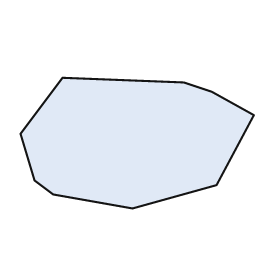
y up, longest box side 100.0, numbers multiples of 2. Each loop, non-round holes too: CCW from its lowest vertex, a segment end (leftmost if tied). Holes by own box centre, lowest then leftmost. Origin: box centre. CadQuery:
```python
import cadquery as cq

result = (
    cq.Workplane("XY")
    .moveTo(-2.0, -28.0)
    .lineTo(34.0, -18.0)
    .lineTo(50.0, 12.0)
    .lineTo(32.0, 22.0)
    .lineTo(20.0, 26.0)
    .lineTo(-32.0, 28.0)
    .lineTo(-50.0, 4.0)
    .lineTo(-44.0, -16.0)
    .lineTo(-36.0, -22.0)
    .close()
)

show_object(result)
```